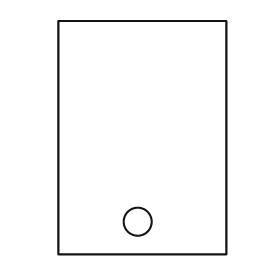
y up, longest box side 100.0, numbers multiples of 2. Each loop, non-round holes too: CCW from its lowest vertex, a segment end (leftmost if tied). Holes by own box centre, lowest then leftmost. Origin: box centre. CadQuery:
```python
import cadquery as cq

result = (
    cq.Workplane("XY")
    .moveTo(-36.0, -50.0)
    .lineTo(36.0, -50.0)
    .lineTo(36.0, 50.0)
    .lineTo(-36.0, 50.0)
    .close()
    .moveTo(-2.0, -36.0)
    .circle(6.0)
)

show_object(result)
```